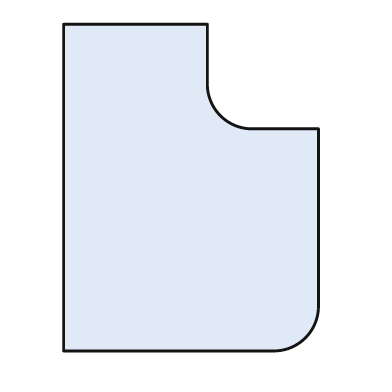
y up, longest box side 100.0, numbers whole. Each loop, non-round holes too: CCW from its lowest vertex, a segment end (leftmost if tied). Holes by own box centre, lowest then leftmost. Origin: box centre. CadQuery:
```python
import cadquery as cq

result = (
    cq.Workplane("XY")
    .moveTo(-39.0, -50.0)
    .lineTo(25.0, -50.0)
    .threePointArc((35.0, -46.0), (39.0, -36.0))
    .lineTo(39.0, 18.0)
    .lineTo(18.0, 18.0)
    .threePointArc((9.0, 22.0), (5.0, 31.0))
    .lineTo(5.0, 50.0)
    .lineTo(-39.0, 50.0)
    .close()
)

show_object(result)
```